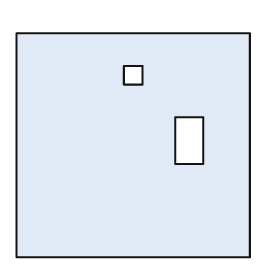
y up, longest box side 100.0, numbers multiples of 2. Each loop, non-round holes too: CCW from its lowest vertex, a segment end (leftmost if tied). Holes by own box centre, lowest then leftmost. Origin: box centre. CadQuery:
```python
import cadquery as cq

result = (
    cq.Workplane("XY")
    .moveTo(-50.0, -48.0)
    .lineTo(50.0, -48.0)
    .lineTo(50.0, 48.0)
    .lineTo(-50.0, 48.0)
    .close()
    .moveTo(18.0, -8.0)
    .lineTo(30.0, -8.0)
    .lineTo(30.0, 12.0)
    .lineTo(18.0, 12.0)
    .close()
    .moveTo(-4.0, 26.0)
    .lineTo(4.0, 26.0)
    .lineTo(4.0, 34.0)
    .lineTo(-4.0, 34.0)
    .close()
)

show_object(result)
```